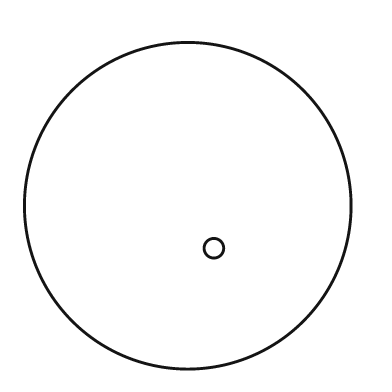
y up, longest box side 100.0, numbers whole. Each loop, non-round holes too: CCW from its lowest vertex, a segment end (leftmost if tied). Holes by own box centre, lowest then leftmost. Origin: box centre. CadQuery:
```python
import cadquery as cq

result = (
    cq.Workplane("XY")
    .moveTo(0.0, 0.0)
    .circle(50.0)
    .moveTo(8.0, -13.0)
    .circle(3.0)
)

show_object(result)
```